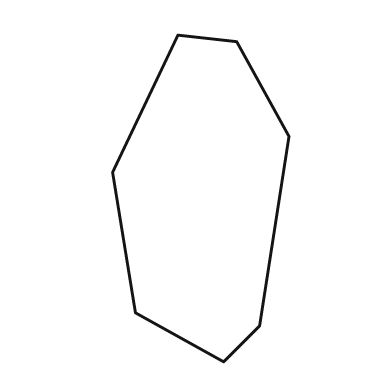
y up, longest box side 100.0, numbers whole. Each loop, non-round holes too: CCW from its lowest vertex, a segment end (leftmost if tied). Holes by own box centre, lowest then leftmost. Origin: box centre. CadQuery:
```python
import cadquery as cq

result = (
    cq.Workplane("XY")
    .moveTo(7.0, -50.0)
    .lineTo(18.0, -39.0)
    .lineTo(27.0, 19.0)
    .lineTo(11.0, 48.0)
    .lineTo(-7.0, 50.0)
    .lineTo(-27.0, 8.0)
    .lineTo(-20.0, -35.0)
    .close()
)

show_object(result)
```